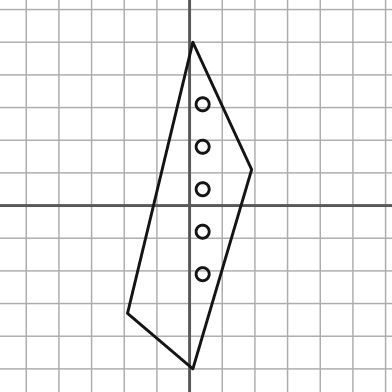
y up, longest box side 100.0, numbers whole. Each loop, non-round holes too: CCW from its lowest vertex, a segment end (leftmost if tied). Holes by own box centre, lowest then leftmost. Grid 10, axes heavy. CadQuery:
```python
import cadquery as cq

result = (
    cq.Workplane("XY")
    .moveTo(1.0, -50.0)
    .lineTo(19.0, 11.0)
    .lineTo(1.0, 50.0)
    .lineTo(-19.0, -33.0)
    .close()
    .moveTo(4.0, -21.0)
    .circle(2.0)
    .moveTo(4.0, -8.0)
    .circle(2.0)
    .moveTo(4.0, 5.0)
    .circle(2.0)
    .moveTo(4.0, 18.0)
    .circle(2.0)
    .moveTo(4.0, 31.0)
    .circle(2.0)
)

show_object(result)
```